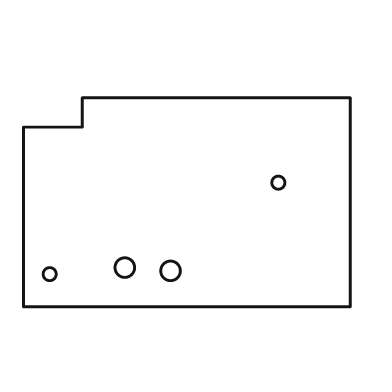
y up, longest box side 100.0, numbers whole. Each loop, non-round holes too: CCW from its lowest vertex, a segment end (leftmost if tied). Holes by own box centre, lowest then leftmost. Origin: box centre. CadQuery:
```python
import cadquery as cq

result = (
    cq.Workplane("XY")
    .moveTo(-50.0, -32.0)
    .lineTo(50.0, -32.0)
    .lineTo(50.0, 32.0)
    .lineTo(-32.0, 32.0)
    .lineTo(-32.0, 23.0)
    .lineTo(-50.0, 23.0)
    .close()
    .moveTo(-42.0, -22.0)
    .circle(2.0)
    .moveTo(-5.0, -21.0)
    .circle(3.0)
    .moveTo(-19.0, -20.0)
    .circle(3.0)
    .moveTo(28.0, 6.0)
    .circle(2.0)
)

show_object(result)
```